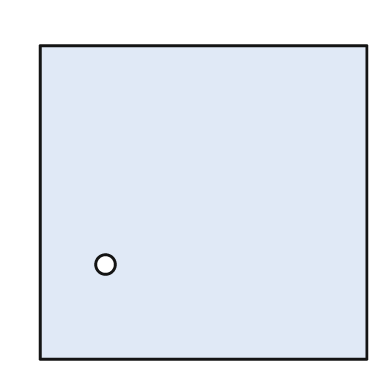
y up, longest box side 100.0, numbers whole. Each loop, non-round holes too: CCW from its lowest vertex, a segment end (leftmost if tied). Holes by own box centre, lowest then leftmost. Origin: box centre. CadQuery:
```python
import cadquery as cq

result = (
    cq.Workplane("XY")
    .moveTo(-50.0, -48.0)
    .lineTo(50.0, -48.0)
    .lineTo(50.0, 48.0)
    .lineTo(-50.0, 48.0)
    .close()
    .moveTo(-30.0, -19.0)
    .circle(3.0)
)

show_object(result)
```